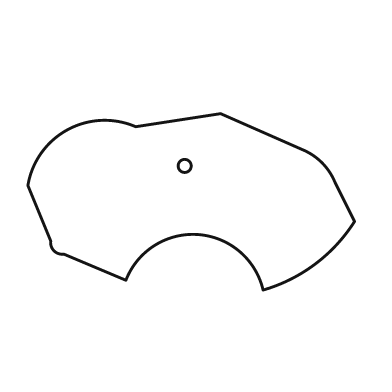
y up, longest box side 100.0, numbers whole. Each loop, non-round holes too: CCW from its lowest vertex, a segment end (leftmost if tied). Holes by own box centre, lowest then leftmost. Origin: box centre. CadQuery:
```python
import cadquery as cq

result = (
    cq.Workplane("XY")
    .moveTo(22.0, -27.0)
    .threePointArc((38.0, -19.0), (50.0, -6.0))
    .lineTo(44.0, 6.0)
    .threePointArc((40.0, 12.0), (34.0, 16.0))
    .lineTo(9.0, 27.0)
    .lineTo(-17.0, 23.0)
    .threePointArc((-38.0, 22.0), (-50.0, 5.0))
    .lineTo(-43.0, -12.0)
    .threePointArc((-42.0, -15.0), (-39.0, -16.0))
    .lineTo(-20.0, -24.0)
    .threePointArc((2.0, -10.0), (22.0, -27.0))
    .close()
    .moveTo(-2.0, 11.0)
    .circle(2.0)
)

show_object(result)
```